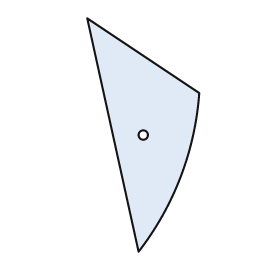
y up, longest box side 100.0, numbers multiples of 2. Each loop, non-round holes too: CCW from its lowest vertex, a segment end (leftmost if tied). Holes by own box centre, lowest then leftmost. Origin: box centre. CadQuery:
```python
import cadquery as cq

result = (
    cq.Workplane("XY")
    .moveTo(-2.0, -50.0)
    .threePointArc((16.0, -18.0), (24.0, 18.0))
    .lineTo(-24.0, 50.0)
    .close()
    .moveTo(0.0, 0.0)
    .circle(2.0)
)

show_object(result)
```